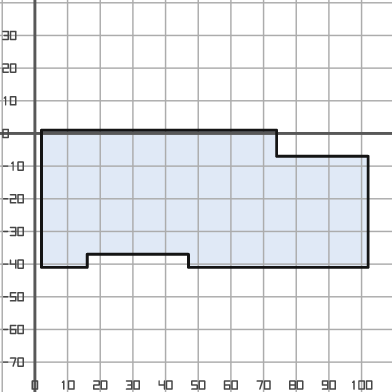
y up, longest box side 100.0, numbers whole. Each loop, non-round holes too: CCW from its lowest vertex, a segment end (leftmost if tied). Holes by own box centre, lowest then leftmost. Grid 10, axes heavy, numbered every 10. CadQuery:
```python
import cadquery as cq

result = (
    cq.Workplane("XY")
    .moveTo(2.0, -41.0)
    .lineTo(16.0, -41.0)
    .lineTo(16.0, -37.0)
    .lineTo(47.0, -37.0)
    .lineTo(47.0, -41.0)
    .lineTo(102.0, -41.0)
    .lineTo(102.0, -7.0)
    .lineTo(74.0, -7.0)
    .lineTo(74.0, 1.0)
    .lineTo(2.0, 1.0)
    .close()
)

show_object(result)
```